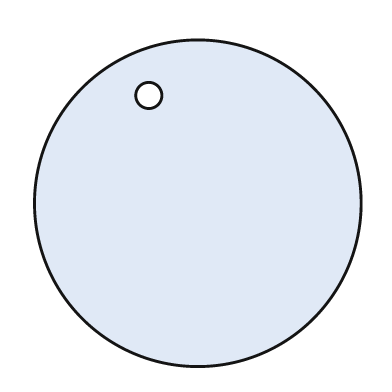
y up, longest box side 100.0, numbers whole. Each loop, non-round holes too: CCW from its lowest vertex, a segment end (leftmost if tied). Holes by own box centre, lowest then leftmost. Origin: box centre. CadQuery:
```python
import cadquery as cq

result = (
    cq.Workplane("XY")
    .moveTo(0.0, 0.0)
    .circle(50.0)
    .moveTo(-15.0, 33.0)
    .circle(4.0)
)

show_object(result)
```